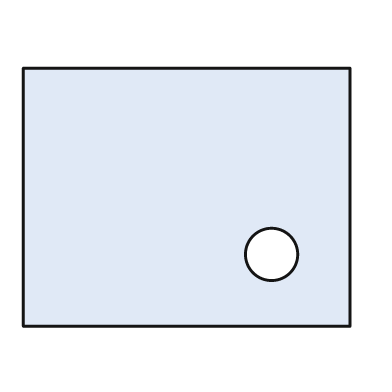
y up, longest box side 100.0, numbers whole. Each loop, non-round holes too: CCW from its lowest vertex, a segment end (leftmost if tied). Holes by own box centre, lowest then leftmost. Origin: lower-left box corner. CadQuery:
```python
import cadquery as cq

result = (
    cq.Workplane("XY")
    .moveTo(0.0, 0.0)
    .lineTo(100.0, 0.0)
    .lineTo(100.0, 79.0)
    .lineTo(0.0, 79.0)
    .close()
    .moveTo(76.0, 22.0)
    .circle(8.0)
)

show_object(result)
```